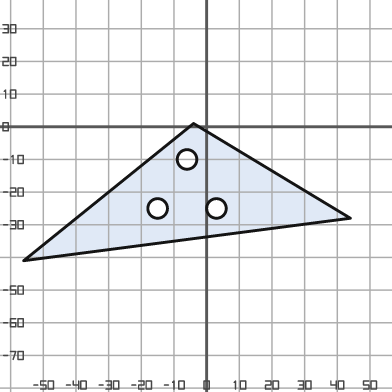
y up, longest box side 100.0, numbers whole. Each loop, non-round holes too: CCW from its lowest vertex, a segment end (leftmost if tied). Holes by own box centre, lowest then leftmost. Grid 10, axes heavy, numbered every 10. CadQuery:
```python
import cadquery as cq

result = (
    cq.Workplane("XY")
    .moveTo(-56.0, -41.0)
    .lineTo(44.0, -28.0)
    .lineTo(-4.0, 1.0)
    .close()
    .moveTo(-15.0, -25.0)
    .circle(3.0)
    .moveTo(3.0, -25.0)
    .circle(3.0)
    .moveTo(-6.0, -10.0)
    .circle(3.0)
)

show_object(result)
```